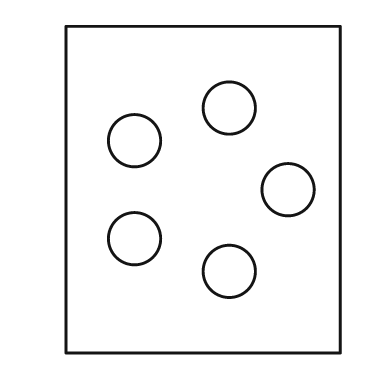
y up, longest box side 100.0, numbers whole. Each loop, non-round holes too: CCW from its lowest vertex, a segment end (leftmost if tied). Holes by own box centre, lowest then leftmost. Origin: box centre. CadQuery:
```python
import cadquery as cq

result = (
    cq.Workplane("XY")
    .moveTo(-42.0, -50.0)
    .lineTo(42.0, -50.0)
    .lineTo(42.0, 50.0)
    .lineTo(-42.0, 50.0)
    .close()
    .moveTo(8.0, -25.0)
    .circle(8.0)
    .moveTo(-21.0, -15.0)
    .circle(8.0)
    .moveTo(26.0, 0.0)
    .circle(8.0)
    .moveTo(-21.0, 15.0)
    .circle(8.0)
    .moveTo(8.0, 25.0)
    .circle(8.0)
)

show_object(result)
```